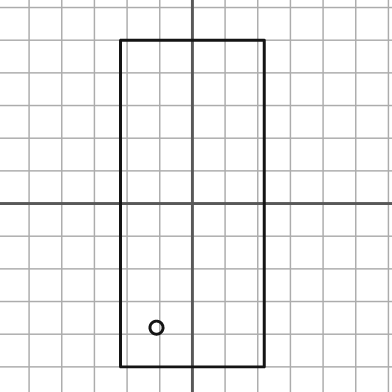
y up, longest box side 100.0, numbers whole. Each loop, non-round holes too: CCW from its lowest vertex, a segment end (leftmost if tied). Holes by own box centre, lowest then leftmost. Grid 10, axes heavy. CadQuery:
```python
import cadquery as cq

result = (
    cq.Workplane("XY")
    .moveTo(-22.0, -50.0)
    .lineTo(22.0, -50.0)
    .lineTo(22.0, 50.0)
    .lineTo(-22.0, 50.0)
    .close()
    .moveTo(-11.0, -38.0)
    .circle(2.0)
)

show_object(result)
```